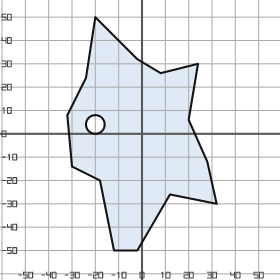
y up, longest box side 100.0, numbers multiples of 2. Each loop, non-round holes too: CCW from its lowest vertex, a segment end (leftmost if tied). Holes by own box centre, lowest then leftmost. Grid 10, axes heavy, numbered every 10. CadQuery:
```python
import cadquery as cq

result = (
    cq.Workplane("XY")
    .moveTo(-12.0, -50.0)
    .lineTo(-2.0, -50.0)
    .lineTo(12.0, -26.0)
    .lineTo(32.0, -30.0)
    .lineTo(28.0, -12.0)
    .lineTo(20.0, 6.0)
    .lineTo(24.0, 30.0)
    .lineTo(8.0, 26.0)
    .lineTo(-2.0, 32.0)
    .lineTo(-20.0, 50.0)
    .lineTo(-24.0, 24.0)
    .lineTo(-32.0, 8.0)
    .lineTo(-30.0, -14.0)
    .lineTo(-18.0, -20.0)
    .close()
    .moveTo(-20.0, 4.0)
    .circle(4.0)
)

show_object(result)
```